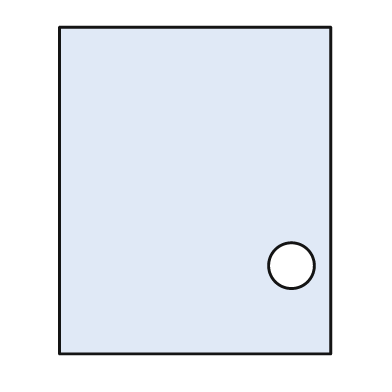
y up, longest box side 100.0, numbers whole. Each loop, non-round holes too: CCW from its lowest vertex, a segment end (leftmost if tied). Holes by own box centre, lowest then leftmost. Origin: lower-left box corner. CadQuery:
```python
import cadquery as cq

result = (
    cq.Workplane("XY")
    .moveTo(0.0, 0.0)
    .lineTo(83.0, 0.0)
    .lineTo(83.0, 100.0)
    .lineTo(0.0, 100.0)
    .close()
    .moveTo(71.0, 27.0)
    .circle(7.0)
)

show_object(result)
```